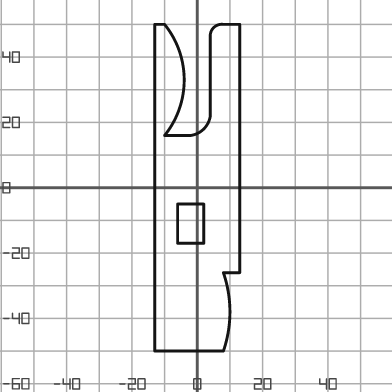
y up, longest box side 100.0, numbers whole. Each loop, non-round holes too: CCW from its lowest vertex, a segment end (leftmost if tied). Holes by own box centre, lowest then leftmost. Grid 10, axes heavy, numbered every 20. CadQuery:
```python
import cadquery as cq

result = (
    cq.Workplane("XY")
    .moveTo(-13.0, -50.0)
    .lineTo(8.0, -50.0)
    .threePointArc((10.0, -38.0), (8.0, -26.0))
    .lineTo(13.0, -26.0)
    .lineTo(13.0, 50.0)
    .lineTo(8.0, 50.0)
    .threePointArc((5.0, 49.0), (4.0, 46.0))
    .lineTo(4.0, 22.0)
    .threePointArc((2.0, 18.0), (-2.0, 16.0))
    .lineTo(-10.0, 16.0)
    .threePointArc((-4.0, 33.0), (-10.0, 50.0))
    .lineTo(-13.0, 50.0)
    .close()
    .moveTo(-6.0, -17.0)
    .lineTo(2.0, -17.0)
    .lineTo(2.0, -5.0)
    .lineTo(-6.0, -5.0)
    .close()
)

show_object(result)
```